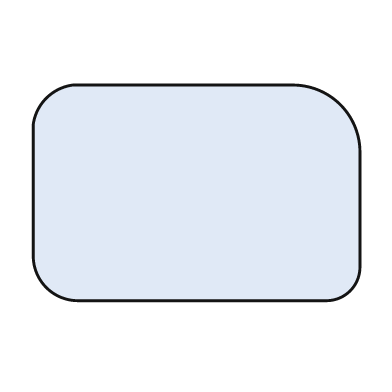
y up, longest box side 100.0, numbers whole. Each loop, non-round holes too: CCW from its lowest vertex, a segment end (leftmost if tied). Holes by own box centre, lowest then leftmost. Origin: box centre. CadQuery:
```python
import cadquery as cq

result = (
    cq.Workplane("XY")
    .moveTo(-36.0, -33.0)
    .lineTo(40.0, -33.0)
    .threePointArc((47.0, -30.0), (50.0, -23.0))
    .lineTo(50.0, 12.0)
    .threePointArc((44.0, 27.0), (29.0, 33.0))
    .lineTo(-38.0, 33.0)
    .threePointArc((-46.0, 29.0), (-50.0, 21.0))
    .lineTo(-50.0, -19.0)
    .threePointArc((-46.0, -29.0), (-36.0, -33.0))
    .close()
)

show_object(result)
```